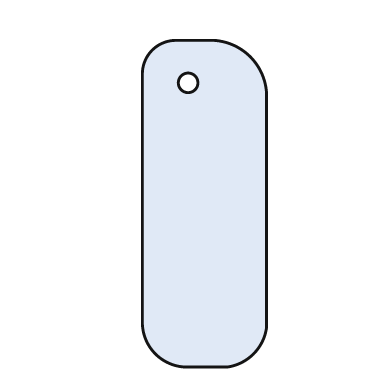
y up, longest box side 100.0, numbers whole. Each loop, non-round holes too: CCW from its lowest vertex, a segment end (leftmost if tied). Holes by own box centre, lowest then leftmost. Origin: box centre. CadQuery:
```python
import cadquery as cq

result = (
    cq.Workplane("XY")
    .moveTo(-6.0, -50.0)
    .lineTo(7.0, -50.0)
    .threePointArc((15.0, -46.0), (19.0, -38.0))
    .lineTo(19.0, 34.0)
    .threePointArc((14.0, 45.0), (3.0, 50.0))
    .lineTo(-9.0, 50.0)
    .threePointArc((-16.0, 47.0), (-19.0, 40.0))
    .lineTo(-19.0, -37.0)
    .threePointArc((-15.0, -46.0), (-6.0, -50.0))
    .close()
    .moveTo(-5.0, 37.0)
    .circle(3.0)
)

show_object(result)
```